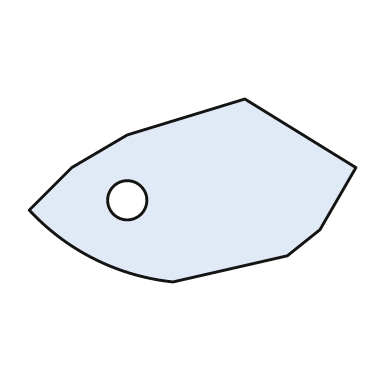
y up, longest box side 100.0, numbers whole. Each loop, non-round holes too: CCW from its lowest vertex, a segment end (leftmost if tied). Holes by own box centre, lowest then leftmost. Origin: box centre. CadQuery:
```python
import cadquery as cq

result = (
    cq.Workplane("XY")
    .moveTo(-6.0, -28.0)
    .lineTo(29.0, -20.0)
    .lineTo(39.0, -12.0)
    .lineTo(50.0, 7.0)
    .lineTo(16.0, 28.0)
    .lineTo(-20.0, 17.0)
    .lineTo(-37.0, 7.0)
    .lineTo(-50.0, -6.0)
    .threePointArc((-30.0, -21.0), (-6.0, -28.0))
    .close()
    .moveTo(-20.0, -3.0)
    .circle(6.0)
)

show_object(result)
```